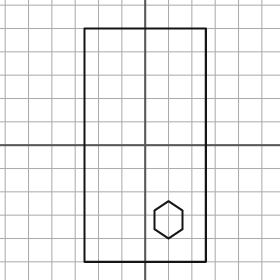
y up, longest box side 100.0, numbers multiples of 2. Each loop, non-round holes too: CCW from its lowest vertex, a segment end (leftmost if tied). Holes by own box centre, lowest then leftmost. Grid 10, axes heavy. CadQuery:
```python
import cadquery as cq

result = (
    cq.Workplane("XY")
    .moveTo(-26.0, -50.0)
    .lineTo(26.0, -50.0)
    .lineTo(26.0, 50.0)
    .lineTo(-26.0, 50.0)
    .close()
    .moveTo(10.0, -40.0)
    .lineTo(16.0, -36.0)
    .lineTo(16.0, -28.0)
    .lineTo(10.0, -24.0)
    .lineTo(4.0, -28.0)
    .lineTo(4.0, -36.0)
    .close()
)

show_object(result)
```